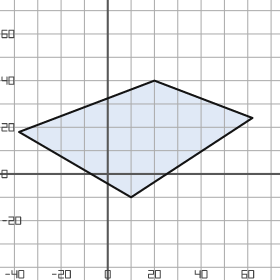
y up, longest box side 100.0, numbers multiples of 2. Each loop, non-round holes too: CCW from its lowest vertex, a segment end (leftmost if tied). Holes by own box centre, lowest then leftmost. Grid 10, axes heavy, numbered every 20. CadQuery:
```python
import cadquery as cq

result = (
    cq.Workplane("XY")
    .moveTo(10.0, -10.0)
    .lineTo(62.0, 24.0)
    .lineTo(20.0, 40.0)
    .lineTo(-38.0, 18.0)
    .close()
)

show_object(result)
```